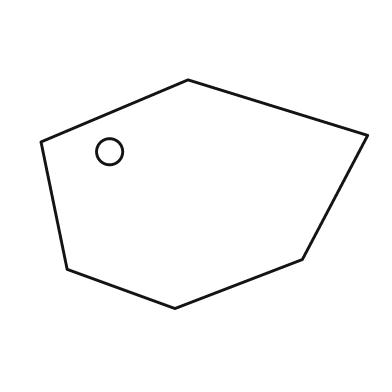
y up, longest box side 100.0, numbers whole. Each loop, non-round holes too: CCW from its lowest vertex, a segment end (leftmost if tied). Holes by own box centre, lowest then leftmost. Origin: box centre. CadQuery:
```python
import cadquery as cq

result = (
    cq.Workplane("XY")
    .moveTo(-9.0, -35.0)
    .lineTo(30.0, -20.0)
    .lineTo(50.0, 18.0)
    .lineTo(-5.0, 35.0)
    .lineTo(-50.0, 16.0)
    .lineTo(-42.0, -23.0)
    .close()
    .moveTo(-29.0, 13.0)
    .circle(4.0)
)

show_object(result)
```